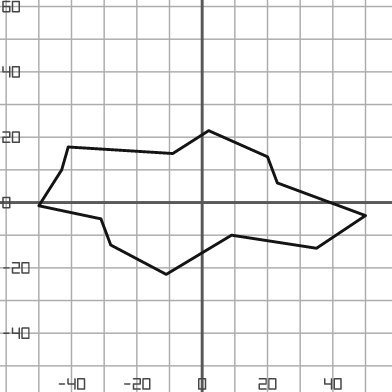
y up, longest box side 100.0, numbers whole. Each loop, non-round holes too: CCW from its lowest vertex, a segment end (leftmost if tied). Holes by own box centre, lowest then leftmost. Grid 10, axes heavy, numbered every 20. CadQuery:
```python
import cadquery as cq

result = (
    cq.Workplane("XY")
    .moveTo(-11.0, -22.0)
    .lineTo(9.0, -10.0)
    .lineTo(35.0, -14.0)
    .lineTo(50.0, -4.0)
    .lineTo(23.0, 6.0)
    .lineTo(20.0, 14.0)
    .lineTo(2.0, 22.0)
    .lineTo(-9.0, 15.0)
    .lineTo(-41.0, 17.0)
    .lineTo(-43.0, 10.0)
    .lineTo(-50.0, -1.0)
    .lineTo(-31.0, -5.0)
    .lineTo(-28.0, -13.0)
    .close()
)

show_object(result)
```